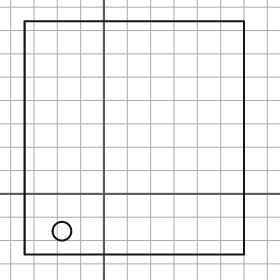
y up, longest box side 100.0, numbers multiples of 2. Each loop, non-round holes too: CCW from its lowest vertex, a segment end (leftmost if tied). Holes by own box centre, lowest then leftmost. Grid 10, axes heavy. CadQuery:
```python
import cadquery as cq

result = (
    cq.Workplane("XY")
    .moveTo(-34.0, -26.0)
    .lineTo(60.0, -26.0)
    .lineTo(60.0, 74.0)
    .lineTo(-34.0, 74.0)
    .close()
    .moveTo(-18.0, -16.0)
    .circle(4.0)
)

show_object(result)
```